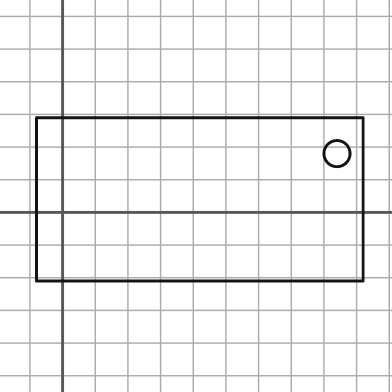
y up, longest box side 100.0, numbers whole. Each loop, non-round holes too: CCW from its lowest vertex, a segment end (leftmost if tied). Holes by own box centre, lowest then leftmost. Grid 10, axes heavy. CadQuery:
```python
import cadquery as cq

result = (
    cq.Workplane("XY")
    .moveTo(-8.0, -21.0)
    .lineTo(92.0, -21.0)
    .lineTo(92.0, 29.0)
    .lineTo(-8.0, 29.0)
    .close()
    .moveTo(84.0, 18.0)
    .circle(4.0)
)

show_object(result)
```